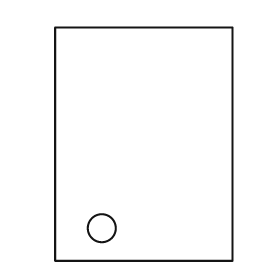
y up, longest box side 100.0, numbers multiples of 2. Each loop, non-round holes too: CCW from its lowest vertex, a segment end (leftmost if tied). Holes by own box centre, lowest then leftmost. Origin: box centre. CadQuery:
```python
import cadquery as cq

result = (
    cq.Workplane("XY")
    .moveTo(-38.0, -50.0)
    .lineTo(38.0, -50.0)
    .lineTo(38.0, 50.0)
    .lineTo(-38.0, 50.0)
    .close()
    .moveTo(-18.0, -36.0)
    .circle(6.0)
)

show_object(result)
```